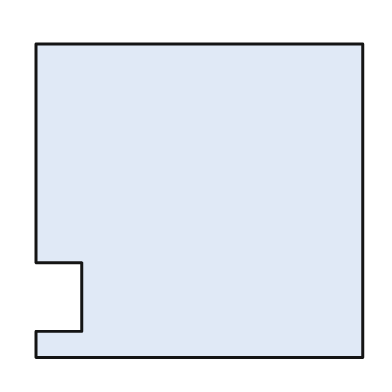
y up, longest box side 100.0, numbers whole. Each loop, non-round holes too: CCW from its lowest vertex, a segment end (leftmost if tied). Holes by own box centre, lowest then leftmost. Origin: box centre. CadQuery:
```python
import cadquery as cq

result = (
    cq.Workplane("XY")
    .moveTo(-50.0, -48.0)
    .lineTo(50.0, -48.0)
    .lineTo(50.0, 48.0)
    .lineTo(-50.0, 48.0)
    .lineTo(-50.0, -19.0)
    .lineTo(-36.0, -19.0)
    .lineTo(-36.0, -40.0)
    .lineTo(-50.0, -40.0)
    .close()
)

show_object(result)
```